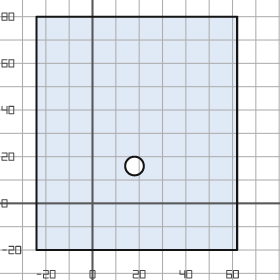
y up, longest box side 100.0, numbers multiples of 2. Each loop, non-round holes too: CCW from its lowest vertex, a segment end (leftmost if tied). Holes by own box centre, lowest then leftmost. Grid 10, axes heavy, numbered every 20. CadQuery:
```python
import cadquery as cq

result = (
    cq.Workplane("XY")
    .moveTo(-24.0, -20.0)
    .lineTo(62.0, -20.0)
    .lineTo(62.0, 80.0)
    .lineTo(-24.0, 80.0)
    .close()
    .moveTo(18.0, 16.0)
    .circle(4.0)
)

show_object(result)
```